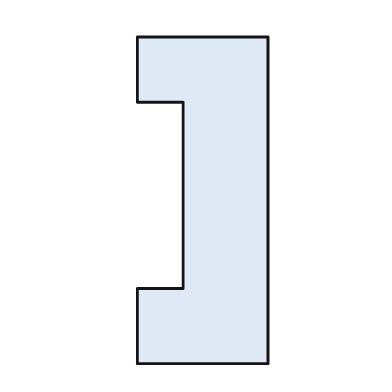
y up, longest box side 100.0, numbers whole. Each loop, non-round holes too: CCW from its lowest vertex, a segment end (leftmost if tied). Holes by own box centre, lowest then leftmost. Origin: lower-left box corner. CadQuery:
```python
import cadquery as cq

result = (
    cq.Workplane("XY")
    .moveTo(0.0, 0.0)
    .lineTo(40.0, 0.0)
    .lineTo(40.0, 100.0)
    .lineTo(0.0, 100.0)
    .lineTo(0.0, 80.0)
    .lineTo(14.0, 80.0)
    .lineTo(14.0, 23.0)
    .lineTo(0.0, 23.0)
    .close()
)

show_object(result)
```